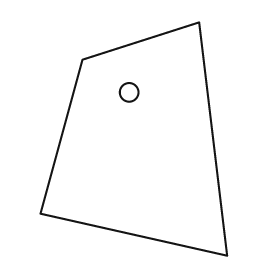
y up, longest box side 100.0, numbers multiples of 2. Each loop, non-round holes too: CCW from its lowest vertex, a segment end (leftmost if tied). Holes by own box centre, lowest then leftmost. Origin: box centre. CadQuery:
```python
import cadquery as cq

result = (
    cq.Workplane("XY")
    .moveTo(40.0, -50.0)
    .lineTo(28.0, 50.0)
    .lineTo(-22.0, 34.0)
    .lineTo(-40.0, -32.0)
    .close()
    .moveTo(-2.0, 20.0)
    .circle(4.0)
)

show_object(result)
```